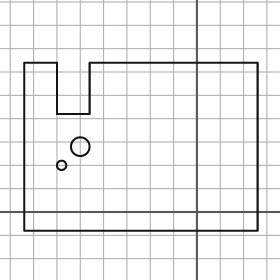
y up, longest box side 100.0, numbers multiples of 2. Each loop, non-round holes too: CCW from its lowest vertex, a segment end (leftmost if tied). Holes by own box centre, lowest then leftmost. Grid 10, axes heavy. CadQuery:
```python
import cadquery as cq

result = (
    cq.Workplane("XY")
    .moveTo(-74.0, -8.0)
    .lineTo(26.0, -8.0)
    .lineTo(26.0, 64.0)
    .lineTo(-46.0, 64.0)
    .lineTo(-46.0, 42.0)
    .lineTo(-60.0, 42.0)
    .lineTo(-60.0, 64.0)
    .lineTo(-74.0, 64.0)
    .close()
    .moveTo(-58.0, 20.0)
    .circle(2.0)
    .moveTo(-50.0, 28.0)
    .circle(4.0)
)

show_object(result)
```